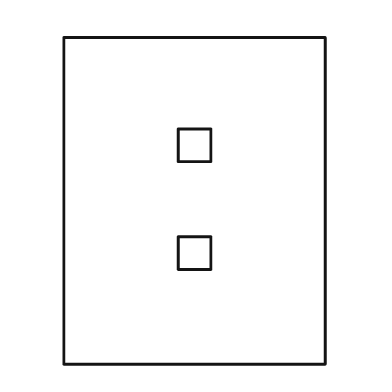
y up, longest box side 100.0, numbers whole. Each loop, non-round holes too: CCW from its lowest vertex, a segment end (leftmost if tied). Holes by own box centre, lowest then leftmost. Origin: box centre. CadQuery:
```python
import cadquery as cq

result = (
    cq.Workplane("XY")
    .moveTo(-40.0, -50.0)
    .lineTo(40.0, -50.0)
    .lineTo(40.0, 50.0)
    .lineTo(-40.0, 50.0)
    .close()
    .moveTo(-5.0, -21.0)
    .lineTo(5.0, -21.0)
    .lineTo(5.0, -11.0)
    .lineTo(-5.0, -11.0)
    .close()
    .moveTo(-5.0, 12.0)
    .lineTo(5.0, 12.0)
    .lineTo(5.0, 22.0)
    .lineTo(-5.0, 22.0)
    .close()
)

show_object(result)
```